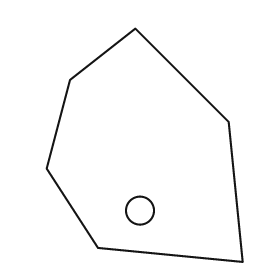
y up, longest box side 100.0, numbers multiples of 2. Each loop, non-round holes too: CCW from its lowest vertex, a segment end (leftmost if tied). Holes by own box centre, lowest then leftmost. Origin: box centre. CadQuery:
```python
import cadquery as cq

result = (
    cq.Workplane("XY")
    .moveTo(42.0, -50.0)
    .lineTo(36.0, 10.0)
    .lineTo(-4.0, 50.0)
    .lineTo(-32.0, 28.0)
    .lineTo(-42.0, -10.0)
    .lineTo(-20.0, -44.0)
    .close()
    .moveTo(-2.0, -28.0)
    .circle(6.0)
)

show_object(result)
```